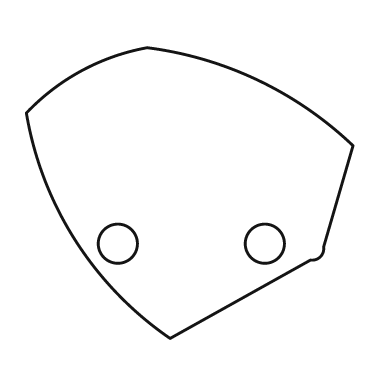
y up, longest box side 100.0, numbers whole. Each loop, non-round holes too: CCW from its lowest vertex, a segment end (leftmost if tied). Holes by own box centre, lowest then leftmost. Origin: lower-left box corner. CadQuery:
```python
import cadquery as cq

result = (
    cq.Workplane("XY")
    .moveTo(44.0, 0.0)
    .lineTo(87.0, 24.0)
    .threePointArc((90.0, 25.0), (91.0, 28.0))
    .lineTo(100.0, 59.0)
    .threePointArc((71.0, 79.0), (37.0, 89.0))
    .threePointArc((17.0, 82.0), (0.0, 69.0))
    .threePointArc((15.0, 30.0), (44.0, 0.0))
    .close()
    .moveTo(28.0, 29.0)
    .circle(6.0)
    .moveTo(73.0, 29.0)
    .circle(6.0)
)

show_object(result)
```